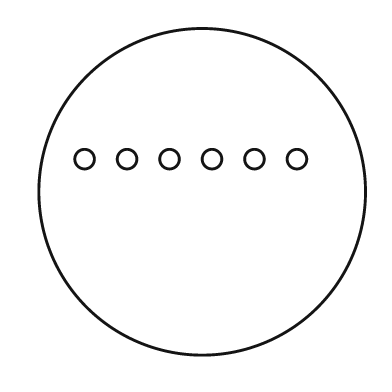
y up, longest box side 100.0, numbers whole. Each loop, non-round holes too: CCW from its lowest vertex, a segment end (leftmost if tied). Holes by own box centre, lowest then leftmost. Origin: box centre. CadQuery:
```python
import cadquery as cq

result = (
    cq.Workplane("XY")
    .moveTo(0.0, 0.0)
    .circle(50.0)
    .moveTo(-36.0, 10.0)
    .circle(3.0)
    .moveTo(-23.0, 10.0)
    .circle(3.0)
    .moveTo(-10.0, 10.0)
    .circle(3.0)
    .moveTo(3.0, 10.0)
    .circle(3.0)
    .moveTo(16.0, 10.0)
    .circle(3.0)
    .moveTo(29.0, 10.0)
    .circle(3.0)
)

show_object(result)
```